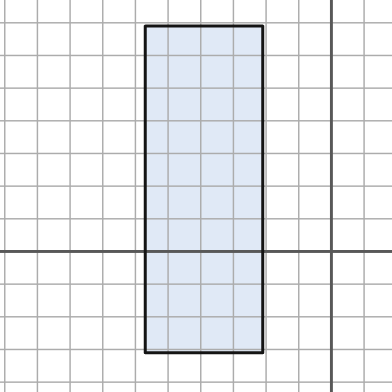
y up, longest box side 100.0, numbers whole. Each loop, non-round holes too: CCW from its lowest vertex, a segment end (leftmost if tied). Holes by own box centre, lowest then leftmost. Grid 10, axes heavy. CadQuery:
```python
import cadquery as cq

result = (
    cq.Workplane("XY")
    .moveTo(-57.0, -31.0)
    .lineTo(-21.0, -31.0)
    .lineTo(-21.0, 69.0)
    .lineTo(-57.0, 69.0)
    .close()
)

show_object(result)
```